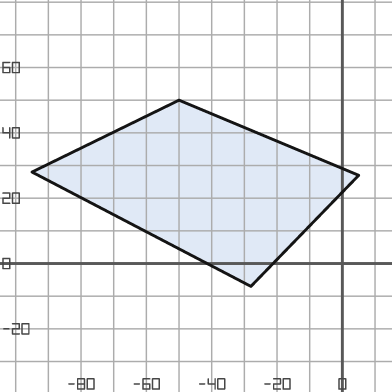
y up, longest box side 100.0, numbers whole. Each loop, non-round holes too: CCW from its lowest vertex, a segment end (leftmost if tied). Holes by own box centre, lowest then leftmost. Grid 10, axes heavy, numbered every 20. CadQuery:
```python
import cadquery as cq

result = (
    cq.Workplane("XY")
    .moveTo(-28.0, -7.0)
    .lineTo(5.0, 27.0)
    .lineTo(-50.0, 50.0)
    .lineTo(-95.0, 28.0)
    .close()
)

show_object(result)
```